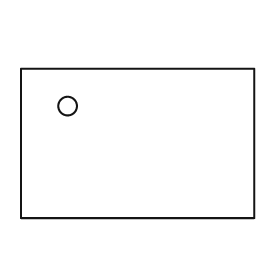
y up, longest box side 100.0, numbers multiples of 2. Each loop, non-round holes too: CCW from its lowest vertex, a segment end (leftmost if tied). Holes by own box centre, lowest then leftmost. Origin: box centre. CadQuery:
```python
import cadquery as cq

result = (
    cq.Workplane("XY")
    .moveTo(-50.0, -32.0)
    .lineTo(50.0, -32.0)
    .lineTo(50.0, 32.0)
    .lineTo(-50.0, 32.0)
    .close()
    .moveTo(-30.0, 16.0)
    .circle(4.0)
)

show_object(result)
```